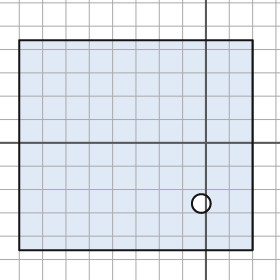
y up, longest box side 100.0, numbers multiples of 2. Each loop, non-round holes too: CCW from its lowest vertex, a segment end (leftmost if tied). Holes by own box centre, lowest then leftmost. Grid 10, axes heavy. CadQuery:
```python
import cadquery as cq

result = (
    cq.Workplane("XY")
    .moveTo(-80.0, -46.0)
    .lineTo(20.0, -46.0)
    .lineTo(20.0, 44.0)
    .lineTo(-80.0, 44.0)
    .close()
    .moveTo(-2.0, -26.0)
    .circle(4.0)
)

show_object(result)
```